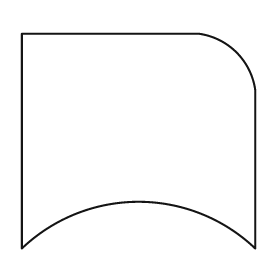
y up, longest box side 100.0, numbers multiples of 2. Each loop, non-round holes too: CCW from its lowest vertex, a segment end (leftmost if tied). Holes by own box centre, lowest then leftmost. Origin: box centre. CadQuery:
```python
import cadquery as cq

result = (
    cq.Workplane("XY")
    .moveTo(-50.0, -46.0)
    .threePointArc((0.0, -26.0), (50.0, -46.0))
    .lineTo(50.0, 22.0)
    .threePointArc((42.0, 38.0), (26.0, 46.0))
    .lineTo(-50.0, 46.0)
    .close()
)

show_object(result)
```